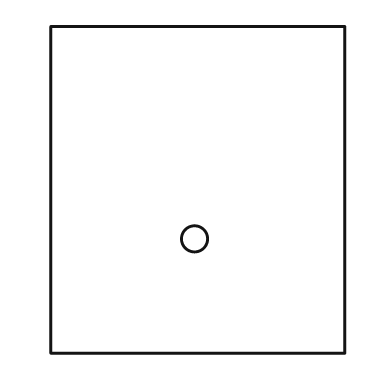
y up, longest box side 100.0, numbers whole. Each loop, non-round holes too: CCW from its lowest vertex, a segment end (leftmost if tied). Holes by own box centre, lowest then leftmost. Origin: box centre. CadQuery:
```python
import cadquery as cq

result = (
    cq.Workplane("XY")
    .moveTo(-45.0, -50.0)
    .lineTo(45.0, -50.0)
    .lineTo(45.0, 50.0)
    .lineTo(-45.0, 50.0)
    .close()
    .moveTo(-1.0, -15.0)
    .circle(4.0)
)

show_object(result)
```